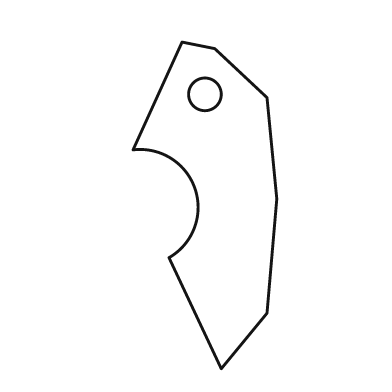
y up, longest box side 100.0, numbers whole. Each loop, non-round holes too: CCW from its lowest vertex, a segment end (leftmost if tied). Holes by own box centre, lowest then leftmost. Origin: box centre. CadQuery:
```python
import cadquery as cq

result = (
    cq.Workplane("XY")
    .moveTo(5.0, -50.0)
    .lineTo(19.0, -33.0)
    .lineTo(22.0, 2.0)
    .lineTo(19.0, 33.0)
    .lineTo(3.0, 48.0)
    .lineTo(-7.0, 50.0)
    .lineTo(-22.0, 17.0)
    .threePointArc((-3.0, 5.0), (-11.0, -16.0))
    .close()
    .moveTo(0.0, 34.0)
    .circle(5.0)
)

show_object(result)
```